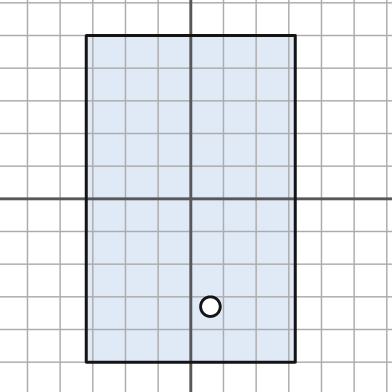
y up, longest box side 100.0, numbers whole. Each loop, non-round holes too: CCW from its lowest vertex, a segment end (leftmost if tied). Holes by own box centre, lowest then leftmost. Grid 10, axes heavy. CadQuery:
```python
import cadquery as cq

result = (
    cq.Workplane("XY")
    .moveTo(-32.0, -50.0)
    .lineTo(32.0, -50.0)
    .lineTo(32.0, 50.0)
    .lineTo(-32.0, 50.0)
    .close()
    .moveTo(6.0, -33.0)
    .circle(3.0)
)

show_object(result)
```